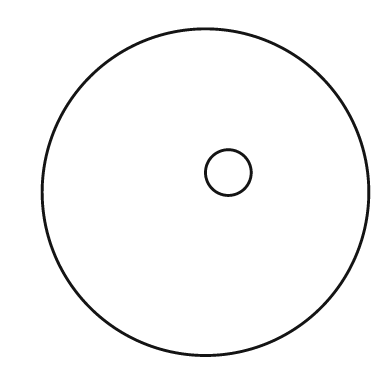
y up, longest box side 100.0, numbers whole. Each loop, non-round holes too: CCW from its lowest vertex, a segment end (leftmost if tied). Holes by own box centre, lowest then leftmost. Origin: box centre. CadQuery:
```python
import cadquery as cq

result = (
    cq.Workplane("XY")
    .moveTo(0.0, 0.0)
    .circle(50.0)
    .moveTo(7.0, 6.0)
    .circle(7.0)
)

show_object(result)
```